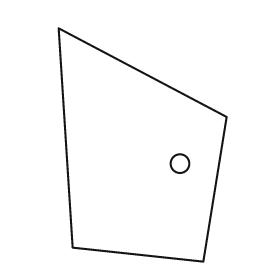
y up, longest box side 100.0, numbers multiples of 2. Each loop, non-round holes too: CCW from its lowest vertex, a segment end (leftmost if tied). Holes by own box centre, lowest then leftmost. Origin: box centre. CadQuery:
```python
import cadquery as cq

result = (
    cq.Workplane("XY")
    .moveTo(26.0, -50.0)
    .lineTo(36.0, 12.0)
    .lineTo(-36.0, 50.0)
    .lineTo(-30.0, -44.0)
    .close()
    .moveTo(16.0, -8.0)
    .circle(4.0)
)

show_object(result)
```